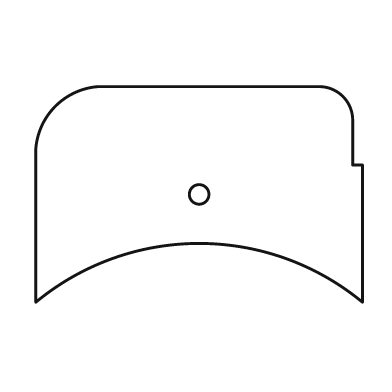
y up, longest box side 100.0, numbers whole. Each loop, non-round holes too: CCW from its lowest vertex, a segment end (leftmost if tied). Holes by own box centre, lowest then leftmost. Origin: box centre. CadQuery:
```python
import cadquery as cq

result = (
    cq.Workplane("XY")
    .moveTo(-50.0, -33.0)
    .threePointArc((0.0, -15.0), (50.0, -33.0))
    .lineTo(50.0, 9.0)
    .lineTo(47.0, 9.0)
    .lineTo(47.0, 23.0)
    .threePointArc((44.0, 30.0), (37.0, 33.0))
    .lineTo(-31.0, 33.0)
    .threePointArc((-44.0, 27.0), (-50.0, 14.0))
    .close()
    .moveTo(0.0, 0.0)
    .circle(3.0)
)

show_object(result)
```